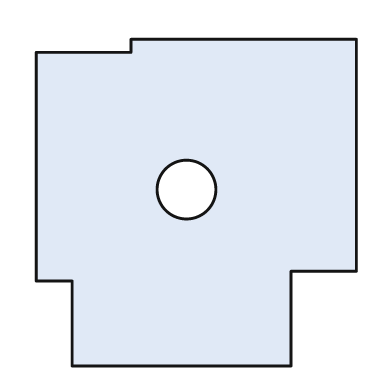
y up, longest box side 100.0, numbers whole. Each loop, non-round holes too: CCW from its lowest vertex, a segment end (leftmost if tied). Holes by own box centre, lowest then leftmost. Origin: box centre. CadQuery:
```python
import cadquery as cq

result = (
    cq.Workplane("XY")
    .moveTo(-38.0, -50.0)
    .lineTo(29.0, -50.0)
    .lineTo(29.0, -21.0)
    .lineTo(49.0, -21.0)
    .lineTo(49.0, 50.0)
    .lineTo(-20.0, 50.0)
    .lineTo(-20.0, 46.0)
    .lineTo(-49.0, 46.0)
    .lineTo(-49.0, -24.0)
    .lineTo(-38.0, -24.0)
    .close()
    .moveTo(-3.0, 4.0)
    .circle(9.0)
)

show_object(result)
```